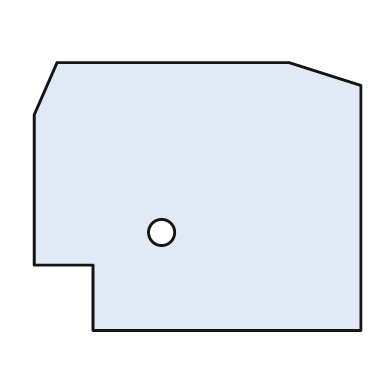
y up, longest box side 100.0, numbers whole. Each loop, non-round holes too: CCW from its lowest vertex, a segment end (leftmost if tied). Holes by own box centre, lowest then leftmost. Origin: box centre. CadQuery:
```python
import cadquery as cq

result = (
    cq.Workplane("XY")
    .moveTo(-32.0, -41.0)
    .lineTo(50.0, -41.0)
    .lineTo(50.0, 34.0)
    .lineTo(28.0, 41.0)
    .lineTo(-43.0, 41.0)
    .lineTo(-50.0, 25.0)
    .lineTo(-50.0, -21.0)
    .lineTo(-32.0, -21.0)
    .close()
    .moveTo(-11.0, -11.0)
    .circle(4.0)
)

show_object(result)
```